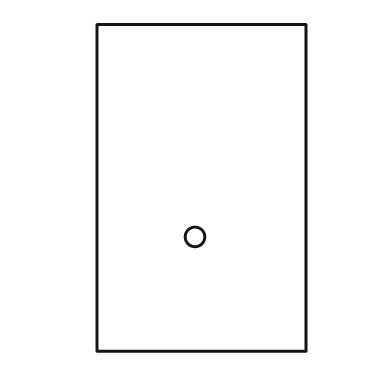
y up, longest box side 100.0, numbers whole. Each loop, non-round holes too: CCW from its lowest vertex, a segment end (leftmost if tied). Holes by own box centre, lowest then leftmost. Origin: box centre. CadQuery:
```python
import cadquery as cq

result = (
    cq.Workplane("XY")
    .moveTo(-32.0, -50.0)
    .lineTo(32.0, -50.0)
    .lineTo(32.0, 50.0)
    .lineTo(-32.0, 50.0)
    .close()
    .moveTo(-2.0, -15.0)
    .circle(3.0)
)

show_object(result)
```